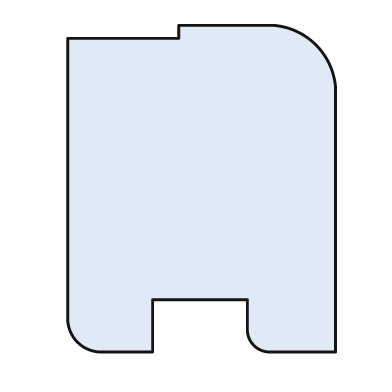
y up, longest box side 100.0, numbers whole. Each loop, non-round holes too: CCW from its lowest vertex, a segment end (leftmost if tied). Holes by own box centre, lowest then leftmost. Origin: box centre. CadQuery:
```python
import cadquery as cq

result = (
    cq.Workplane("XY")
    .moveTo(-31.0, -50.0)
    .lineTo(-15.0, -50.0)
    .lineTo(-15.0, -34.0)
    .lineTo(14.0, -34.0)
    .lineTo(14.0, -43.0)
    .threePointArc((16.0, -48.0), (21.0, -50.0))
    .lineTo(41.0, -50.0)
    .lineTo(41.0, 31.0)
    .threePointArc((35.0, 44.0), (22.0, 50.0))
    .lineTo(-7.0, 50.0)
    .lineTo(-7.0, 46.0)
    .lineTo(-41.0, 46.0)
    .lineTo(-41.0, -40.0)
    .threePointArc((-38.0, -47.0), (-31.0, -50.0))
    .close()
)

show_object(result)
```